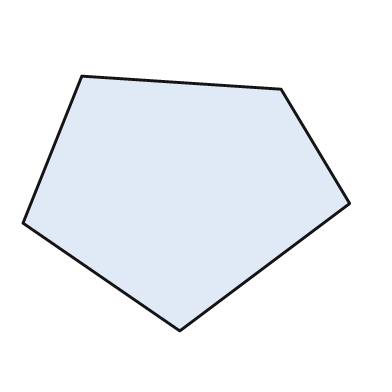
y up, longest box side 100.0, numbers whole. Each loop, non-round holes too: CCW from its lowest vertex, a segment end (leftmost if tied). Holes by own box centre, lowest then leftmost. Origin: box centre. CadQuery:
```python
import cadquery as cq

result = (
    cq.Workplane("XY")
    .moveTo(-2.0, -39.0)
    .lineTo(50.0, 0.0)
    .lineTo(29.0, 35.0)
    .lineTo(-32.0, 39.0)
    .lineTo(-50.0, -6.0)
    .close()
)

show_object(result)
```